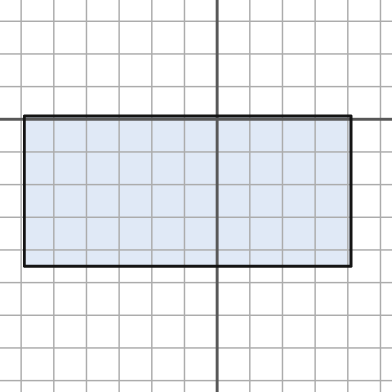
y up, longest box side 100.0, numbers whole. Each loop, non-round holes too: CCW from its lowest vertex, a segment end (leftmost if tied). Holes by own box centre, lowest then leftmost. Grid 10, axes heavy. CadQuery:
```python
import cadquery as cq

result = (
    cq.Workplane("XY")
    .moveTo(-59.0, -45.0)
    .lineTo(41.0, -45.0)
    .lineTo(41.0, 1.0)
    .lineTo(-59.0, 1.0)
    .close()
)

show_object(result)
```